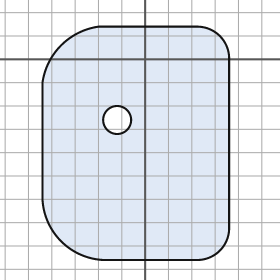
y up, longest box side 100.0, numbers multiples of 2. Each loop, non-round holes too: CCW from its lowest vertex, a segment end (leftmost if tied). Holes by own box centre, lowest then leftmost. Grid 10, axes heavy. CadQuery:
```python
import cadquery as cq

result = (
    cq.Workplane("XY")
    .moveTo(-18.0, -86.0)
    .lineTo(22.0, -86.0)
    .threePointArc((32.0, -82.0), (36.0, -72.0))
    .lineTo(36.0, 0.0)
    .threePointArc((32.0, 10.0), (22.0, 14.0))
    .lineTo(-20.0, 14.0)
    .threePointArc((-36.0, 6.0), (-44.0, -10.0))
    .lineTo(-44.0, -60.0)
    .threePointArc((-36.0, -78.0), (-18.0, -86.0))
    .close()
    .moveTo(-12.0, -26.0)
    .circle(6.0)
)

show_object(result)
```